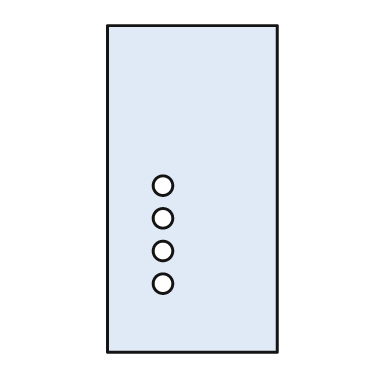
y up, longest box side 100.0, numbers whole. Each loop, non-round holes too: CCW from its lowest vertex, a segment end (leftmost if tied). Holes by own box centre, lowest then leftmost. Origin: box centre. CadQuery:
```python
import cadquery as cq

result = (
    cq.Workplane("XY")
    .moveTo(-26.0, -50.0)
    .lineTo(26.0, -50.0)
    .lineTo(26.0, 50.0)
    .lineTo(-26.0, 50.0)
    .close()
    .moveTo(-9.0, -29.0)
    .circle(3.0)
    .moveTo(-9.0, -19.0)
    .circle(3.0)
    .moveTo(-9.0, -9.0)
    .circle(3.0)
    .moveTo(-9.0, 1.0)
    .circle(3.0)
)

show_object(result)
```